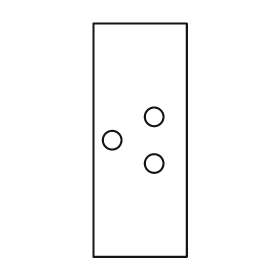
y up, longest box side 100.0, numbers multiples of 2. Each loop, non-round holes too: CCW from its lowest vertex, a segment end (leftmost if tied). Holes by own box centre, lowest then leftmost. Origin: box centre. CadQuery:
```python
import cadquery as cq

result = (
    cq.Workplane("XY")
    .moveTo(-20.0, -50.0)
    .lineTo(20.0, -50.0)
    .lineTo(20.0, 50.0)
    .lineTo(-20.0, 50.0)
    .close()
    .moveTo(6.0, -10.0)
    .circle(4.0)
    .moveTo(-12.0, 0.0)
    .circle(4.0)
    .moveTo(6.0, 10.0)
    .circle(4.0)
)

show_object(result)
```